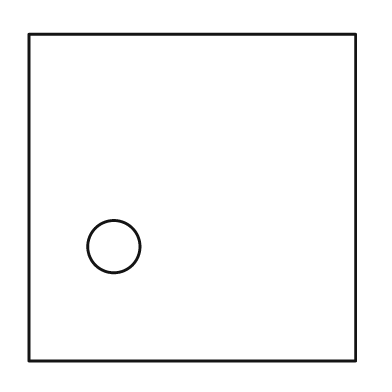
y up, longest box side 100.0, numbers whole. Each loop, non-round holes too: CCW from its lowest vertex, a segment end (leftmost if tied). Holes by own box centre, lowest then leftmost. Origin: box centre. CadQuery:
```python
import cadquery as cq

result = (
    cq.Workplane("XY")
    .moveTo(-50.0, -50.0)
    .lineTo(50.0, -50.0)
    .lineTo(50.0, 50.0)
    .lineTo(-50.0, 50.0)
    .close()
    .moveTo(-24.0, -15.0)
    .circle(8.0)
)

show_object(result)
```